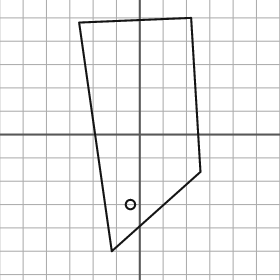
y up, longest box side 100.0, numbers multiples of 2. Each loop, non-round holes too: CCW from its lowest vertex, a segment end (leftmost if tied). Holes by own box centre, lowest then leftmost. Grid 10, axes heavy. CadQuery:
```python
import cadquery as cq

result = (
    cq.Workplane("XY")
    .moveTo(-12.0, -50.0)
    .lineTo(26.0, -16.0)
    .lineTo(22.0, 50.0)
    .lineTo(-26.0, 48.0)
    .close()
    .moveTo(-4.0, -30.0)
    .circle(2.0)
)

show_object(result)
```